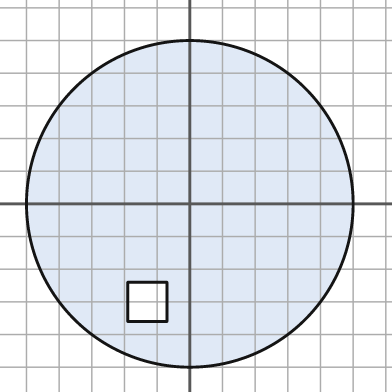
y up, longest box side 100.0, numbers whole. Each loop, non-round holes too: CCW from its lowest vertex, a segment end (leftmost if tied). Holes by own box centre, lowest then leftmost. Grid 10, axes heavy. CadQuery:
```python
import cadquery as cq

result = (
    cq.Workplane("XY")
    .moveTo(0.0, 0.0)
    .circle(50.0)
    .moveTo(-19.0, -36.0)
    .lineTo(-7.0, -36.0)
    .lineTo(-7.0, -24.0)
    .lineTo(-19.0, -24.0)
    .close()
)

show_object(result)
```